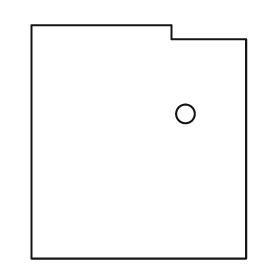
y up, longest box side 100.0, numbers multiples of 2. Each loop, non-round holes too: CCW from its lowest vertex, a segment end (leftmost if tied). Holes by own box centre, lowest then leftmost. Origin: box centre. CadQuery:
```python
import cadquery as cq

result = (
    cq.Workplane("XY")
    .moveTo(-46.0, -50.0)
    .lineTo(46.0, -50.0)
    .lineTo(46.0, 44.0)
    .lineTo(14.0, 44.0)
    .lineTo(14.0, 50.0)
    .lineTo(-46.0, 50.0)
    .close()
    .moveTo(20.0, 12.0)
    .circle(4.0)
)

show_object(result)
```